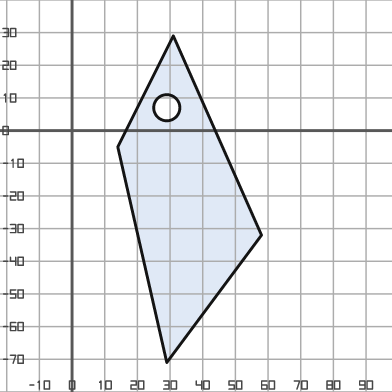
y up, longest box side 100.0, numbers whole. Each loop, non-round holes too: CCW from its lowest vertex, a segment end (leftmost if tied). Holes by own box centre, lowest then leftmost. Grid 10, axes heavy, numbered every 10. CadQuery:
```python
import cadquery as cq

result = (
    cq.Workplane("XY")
    .moveTo(29.0, -71.0)
    .lineTo(58.0, -32.0)
    .lineTo(31.0, 29.0)
    .lineTo(14.0, -5.0)
    .close()
    .moveTo(29.0, 7.0)
    .circle(4.0)
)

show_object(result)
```